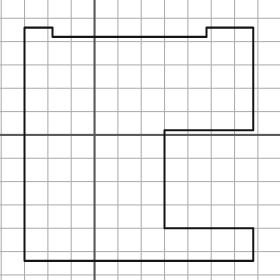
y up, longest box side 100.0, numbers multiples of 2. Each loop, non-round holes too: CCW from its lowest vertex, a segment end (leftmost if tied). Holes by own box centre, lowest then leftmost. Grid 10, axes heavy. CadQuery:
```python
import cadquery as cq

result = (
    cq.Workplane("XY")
    .moveTo(-30.0, -54.0)
    .lineTo(68.0, -54.0)
    .lineTo(68.0, -40.0)
    .lineTo(30.0, -40.0)
    .lineTo(30.0, 2.0)
    .lineTo(68.0, 2.0)
    .lineTo(68.0, 46.0)
    .lineTo(48.0, 46.0)
    .lineTo(48.0, 42.0)
    .lineTo(-18.0, 42.0)
    .lineTo(-18.0, 46.0)
    .lineTo(-30.0, 46.0)
    .close()
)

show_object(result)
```